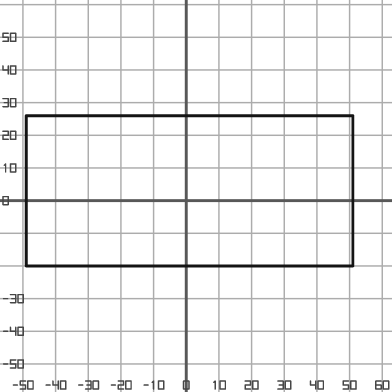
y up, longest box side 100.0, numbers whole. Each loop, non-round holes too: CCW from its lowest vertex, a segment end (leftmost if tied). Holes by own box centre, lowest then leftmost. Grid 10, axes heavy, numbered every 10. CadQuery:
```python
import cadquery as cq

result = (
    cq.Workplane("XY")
    .moveTo(-49.0, -20.0)
    .lineTo(51.0, -20.0)
    .lineTo(51.0, 26.0)
    .lineTo(-49.0, 26.0)
    .close()
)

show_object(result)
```